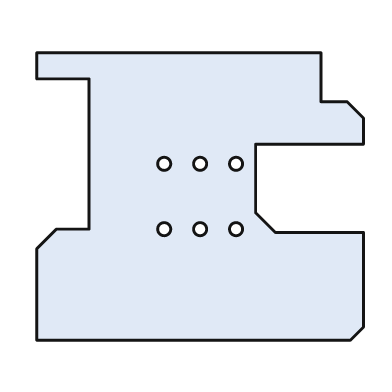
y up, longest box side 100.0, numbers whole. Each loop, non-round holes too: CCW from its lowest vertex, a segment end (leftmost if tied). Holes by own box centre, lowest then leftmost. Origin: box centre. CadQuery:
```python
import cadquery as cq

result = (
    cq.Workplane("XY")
    .moveTo(-50.0, -44.0)
    .lineTo(46.0, -44.0)
    .lineTo(50.0, -40.0)
    .lineTo(50.0, -11.0)
    .lineTo(23.0, -11.0)
    .lineTo(17.0, -5.0)
    .lineTo(17.0, 16.0)
    .lineTo(50.0, 16.0)
    .lineTo(50.0, 24.0)
    .lineTo(45.0, 29.0)
    .lineTo(37.0, 29.0)
    .lineTo(37.0, 44.0)
    .lineTo(-50.0, 44.0)
    .lineTo(-50.0, 36.0)
    .lineTo(-34.0, 36.0)
    .lineTo(-34.0, -10.0)
    .lineTo(-44.0, -10.0)
    .lineTo(-50.0, -16.0)
    .close()
    .moveTo(-11.0, -10.0)
    .circle(2.0)
    .moveTo(0.0, -10.0)
    .circle(2.0)
    .moveTo(11.0, -10.0)
    .circle(2.0)
    .moveTo(-11.0, 10.0)
    .circle(2.0)
    .moveTo(0.0, 10.0)
    .circle(2.0)
    .moveTo(11.0, 10.0)
    .circle(2.0)
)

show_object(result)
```